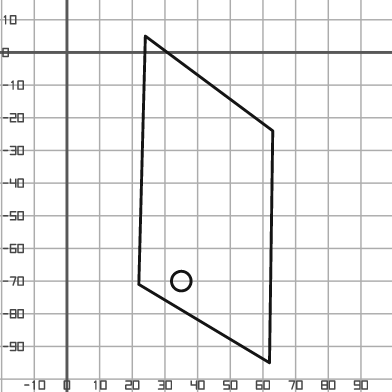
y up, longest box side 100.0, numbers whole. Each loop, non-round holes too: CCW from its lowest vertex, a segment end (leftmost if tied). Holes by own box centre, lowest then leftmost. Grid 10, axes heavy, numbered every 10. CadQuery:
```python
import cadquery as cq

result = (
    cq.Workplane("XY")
    .moveTo(62.0, -95.0)
    .lineTo(63.0, -24.0)
    .lineTo(24.0, 5.0)
    .lineTo(22.0, -71.0)
    .close()
    .moveTo(35.0, -70.0)
    .circle(3.0)
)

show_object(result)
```